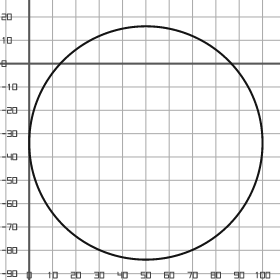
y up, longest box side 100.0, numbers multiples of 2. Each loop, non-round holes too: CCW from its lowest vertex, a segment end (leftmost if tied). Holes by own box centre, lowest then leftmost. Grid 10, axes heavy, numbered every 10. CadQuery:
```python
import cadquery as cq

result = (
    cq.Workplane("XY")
    .moveTo(50.0, -34.0)
    .circle(50.0)
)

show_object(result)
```